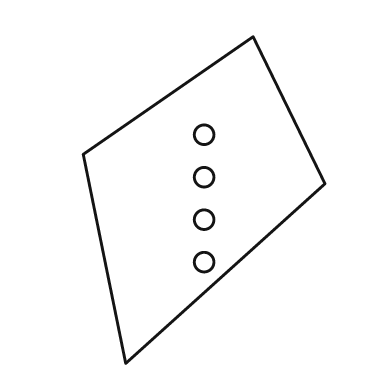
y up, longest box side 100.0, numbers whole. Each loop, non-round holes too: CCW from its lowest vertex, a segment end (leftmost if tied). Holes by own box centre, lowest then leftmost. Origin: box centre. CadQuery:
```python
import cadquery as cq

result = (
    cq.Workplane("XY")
    .moveTo(-24.0, -50.0)
    .lineTo(37.0, 5.0)
    .lineTo(15.0, 50.0)
    .lineTo(-37.0, 14.0)
    .close()
    .moveTo(0.0, -19.0)
    .circle(3.0)
    .moveTo(0.0, -6.0)
    .circle(3.0)
    .moveTo(0.0, 7.0)
    .circle(3.0)
    .moveTo(0.0, 20.0)
    .circle(3.0)
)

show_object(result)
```